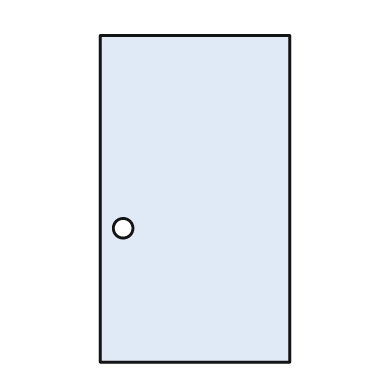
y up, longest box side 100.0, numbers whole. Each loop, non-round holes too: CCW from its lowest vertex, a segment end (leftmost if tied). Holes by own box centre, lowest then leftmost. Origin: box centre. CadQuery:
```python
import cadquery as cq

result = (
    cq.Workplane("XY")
    .moveTo(-29.0, -50.0)
    .lineTo(29.0, -50.0)
    .lineTo(29.0, 50.0)
    .lineTo(-29.0, 50.0)
    .close()
    .moveTo(-22.0, -9.0)
    .circle(3.0)
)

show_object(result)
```